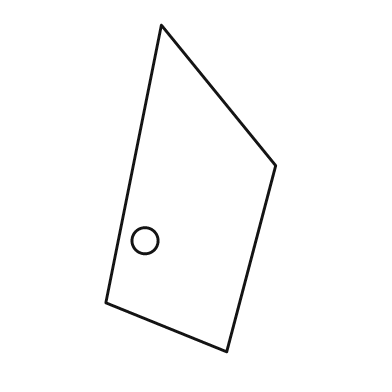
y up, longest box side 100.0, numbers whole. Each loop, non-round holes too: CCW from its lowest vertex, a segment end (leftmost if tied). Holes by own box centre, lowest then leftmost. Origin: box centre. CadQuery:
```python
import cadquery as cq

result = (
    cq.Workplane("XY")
    .moveTo(11.0, -50.0)
    .lineTo(26.0, 7.0)
    .lineTo(-9.0, 50.0)
    .lineTo(-26.0, -35.0)
    .close()
    .moveTo(-14.0, -16.0)
    .circle(4.0)
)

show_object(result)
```